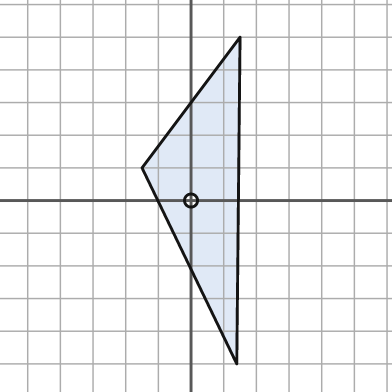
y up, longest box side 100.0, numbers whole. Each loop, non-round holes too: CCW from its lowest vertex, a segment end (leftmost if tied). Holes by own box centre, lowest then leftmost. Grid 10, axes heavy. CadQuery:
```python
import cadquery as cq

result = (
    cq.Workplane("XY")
    .moveTo(14.0, -50.0)
    .lineTo(15.0, 50.0)
    .lineTo(-15.0, 10.0)
    .close()
    .moveTo(0.0, 0.0)
    .circle(2.0)
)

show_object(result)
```